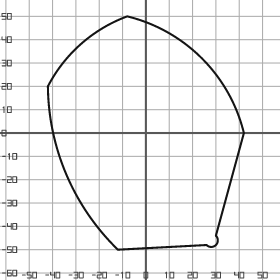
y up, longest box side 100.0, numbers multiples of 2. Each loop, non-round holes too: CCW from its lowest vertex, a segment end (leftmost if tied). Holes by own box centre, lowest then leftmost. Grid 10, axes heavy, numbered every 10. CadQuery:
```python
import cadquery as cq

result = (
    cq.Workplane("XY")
    .moveTo(-12.0, -50.0)
    .lineTo(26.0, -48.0)
    .threePointArc((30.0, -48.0), (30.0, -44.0))
    .lineTo(42.0, 0.0)
    .threePointArc((24.0, 32.0), (-8.0, 50.0))
    .threePointArc((-28.0, 38.0), (-42.0, 20.0))
    .threePointArc((-34.0, -18.0), (-12.0, -50.0))
    .close()
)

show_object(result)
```